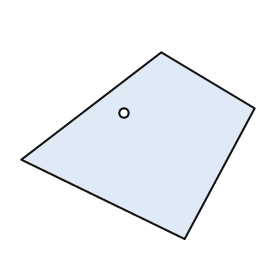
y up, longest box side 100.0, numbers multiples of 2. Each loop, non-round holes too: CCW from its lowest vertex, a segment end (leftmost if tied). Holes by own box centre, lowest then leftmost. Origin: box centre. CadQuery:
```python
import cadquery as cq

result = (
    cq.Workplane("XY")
    .moveTo(20.0, -40.0)
    .lineTo(50.0, 16.0)
    .lineTo(10.0, 40.0)
    .lineTo(-50.0, -6.0)
    .close()
    .moveTo(-6.0, 14.0)
    .circle(2.0)
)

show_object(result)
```